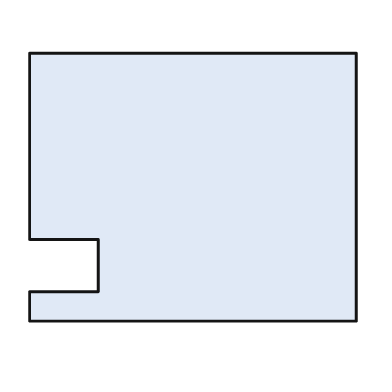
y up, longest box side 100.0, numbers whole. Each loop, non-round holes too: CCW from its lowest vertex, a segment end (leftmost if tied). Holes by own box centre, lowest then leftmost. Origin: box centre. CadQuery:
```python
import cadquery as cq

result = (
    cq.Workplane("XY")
    .moveTo(-50.0, -41.0)
    .lineTo(50.0, -41.0)
    .lineTo(50.0, 41.0)
    .lineTo(-50.0, 41.0)
    .lineTo(-50.0, -16.0)
    .lineTo(-29.0, -16.0)
    .lineTo(-29.0, -32.0)
    .lineTo(-50.0, -32.0)
    .close()
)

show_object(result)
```